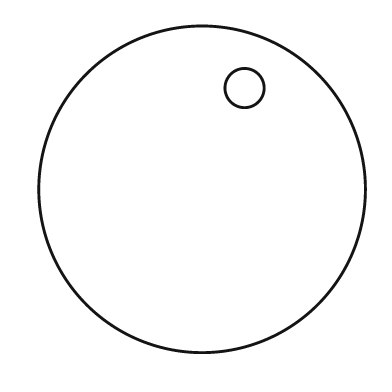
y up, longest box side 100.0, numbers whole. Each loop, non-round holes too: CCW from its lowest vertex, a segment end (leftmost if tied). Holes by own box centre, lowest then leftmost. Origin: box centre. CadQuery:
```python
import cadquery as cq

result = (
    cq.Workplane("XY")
    .moveTo(0.0, 0.0)
    .circle(50.0)
    .moveTo(13.0, 31.0)
    .circle(6.0)
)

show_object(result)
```